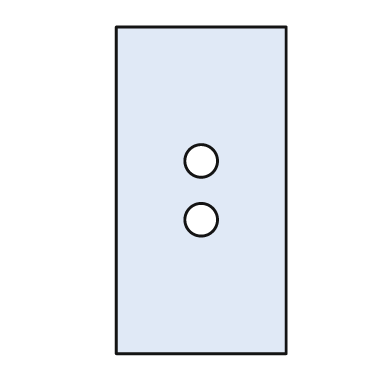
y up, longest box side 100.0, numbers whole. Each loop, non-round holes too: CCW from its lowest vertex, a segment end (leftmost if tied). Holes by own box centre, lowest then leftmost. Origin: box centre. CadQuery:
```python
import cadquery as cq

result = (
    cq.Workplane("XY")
    .moveTo(-26.0, -50.0)
    .lineTo(26.0, -50.0)
    .lineTo(26.0, 50.0)
    .lineTo(-26.0, 50.0)
    .close()
    .moveTo(0.0, -9.0)
    .circle(5.0)
    .moveTo(0.0, 9.0)
    .circle(5.0)
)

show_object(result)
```